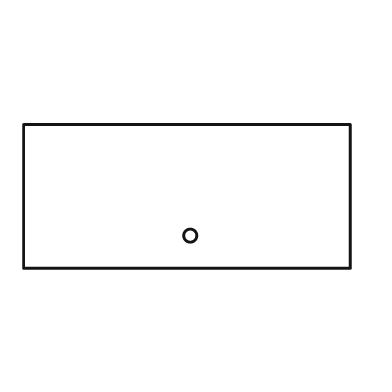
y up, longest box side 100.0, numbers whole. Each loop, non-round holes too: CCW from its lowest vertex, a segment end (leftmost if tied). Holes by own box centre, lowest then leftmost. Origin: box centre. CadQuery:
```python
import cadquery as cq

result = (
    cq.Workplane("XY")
    .moveTo(-50.0, -22.0)
    .lineTo(50.0, -22.0)
    .lineTo(50.0, 22.0)
    .lineTo(-50.0, 22.0)
    .close()
    .moveTo(1.0, -12.0)
    .circle(2.0)
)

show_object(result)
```